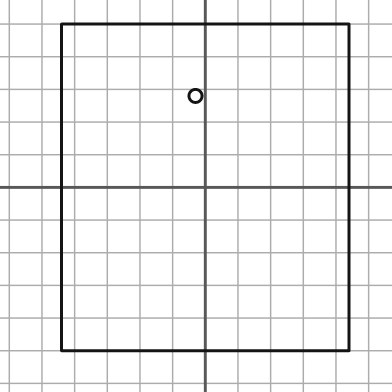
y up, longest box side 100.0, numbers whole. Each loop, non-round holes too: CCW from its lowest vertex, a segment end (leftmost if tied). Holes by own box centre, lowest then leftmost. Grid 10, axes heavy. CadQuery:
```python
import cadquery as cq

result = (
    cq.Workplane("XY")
    .moveTo(-44.0, -50.0)
    .lineTo(44.0, -50.0)
    .lineTo(44.0, 50.0)
    .lineTo(-44.0, 50.0)
    .close()
    .moveTo(-3.0, 28.0)
    .circle(2.0)
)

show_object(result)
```